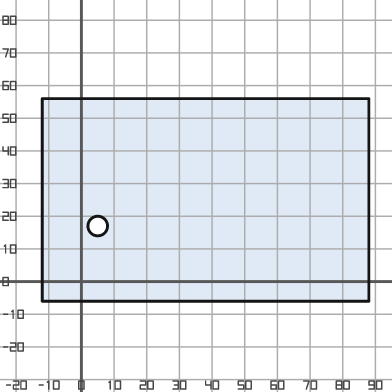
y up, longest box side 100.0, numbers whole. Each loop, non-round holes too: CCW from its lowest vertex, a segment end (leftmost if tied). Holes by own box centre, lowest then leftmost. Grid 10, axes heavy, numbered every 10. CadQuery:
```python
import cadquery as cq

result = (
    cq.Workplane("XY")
    .moveTo(-12.0, -6.0)
    .lineTo(88.0, -6.0)
    .lineTo(88.0, 56.0)
    .lineTo(-12.0, 56.0)
    .close()
    .moveTo(5.0, 17.0)
    .circle(3.0)
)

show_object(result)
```